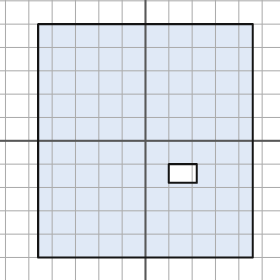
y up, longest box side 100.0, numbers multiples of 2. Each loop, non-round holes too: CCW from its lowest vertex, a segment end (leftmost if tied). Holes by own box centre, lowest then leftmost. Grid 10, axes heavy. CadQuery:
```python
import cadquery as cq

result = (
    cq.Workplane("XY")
    .moveTo(-46.0, -50.0)
    .lineTo(46.0, -50.0)
    .lineTo(46.0, 50.0)
    .lineTo(-46.0, 50.0)
    .close()
    .moveTo(10.0, -18.0)
    .lineTo(22.0, -18.0)
    .lineTo(22.0, -10.0)
    .lineTo(10.0, -10.0)
    .close()
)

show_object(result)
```